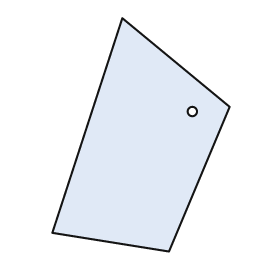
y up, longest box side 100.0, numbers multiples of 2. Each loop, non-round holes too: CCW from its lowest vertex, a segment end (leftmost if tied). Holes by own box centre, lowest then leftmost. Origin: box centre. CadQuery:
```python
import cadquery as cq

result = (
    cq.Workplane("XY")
    .moveTo(12.0, -50.0)
    .lineTo(38.0, 12.0)
    .lineTo(-8.0, 50.0)
    .lineTo(-38.0, -42.0)
    .close()
    .moveTo(22.0, 10.0)
    .circle(2.0)
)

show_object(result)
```